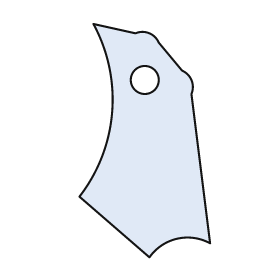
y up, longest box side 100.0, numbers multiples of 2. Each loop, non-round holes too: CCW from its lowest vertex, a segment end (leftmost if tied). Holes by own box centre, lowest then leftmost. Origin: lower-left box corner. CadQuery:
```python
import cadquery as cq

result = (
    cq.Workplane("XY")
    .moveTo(30.0, 0.0)
    .threePointArc((42.0, 8.0), (56.0, 6.0))
    .lineTo(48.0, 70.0)
    .threePointArc((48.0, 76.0), (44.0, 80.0))
    .lineTo(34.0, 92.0)
    .threePointArc((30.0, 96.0), (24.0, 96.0))
    .lineTo(6.0, 100.0)
    .threePointArc((14.0, 62.0), (0.0, 26.0))
    .close()
    .moveTo(28.0, 76.0)
    .circle(6.0)
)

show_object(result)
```